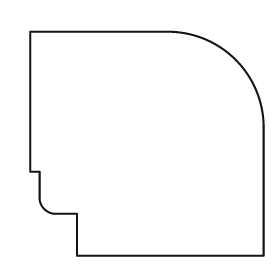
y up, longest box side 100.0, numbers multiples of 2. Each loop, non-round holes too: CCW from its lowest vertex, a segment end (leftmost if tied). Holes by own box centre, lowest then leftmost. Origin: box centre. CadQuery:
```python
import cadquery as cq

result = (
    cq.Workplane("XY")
    .moveTo(-30.0, -48.0)
    .lineTo(50.0, -48.0)
    .lineTo(50.0, 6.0)
    .threePointArc((38.0, 36.0), (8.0, 48.0))
    .lineTo(-50.0, 48.0)
    .lineTo(-50.0, -12.0)
    .lineTo(-46.0, -12.0)
    .lineTo(-46.0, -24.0)
    .threePointArc((-44.0, -28.0), (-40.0, -30.0))
    .lineTo(-30.0, -30.0)
    .close()
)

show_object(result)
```